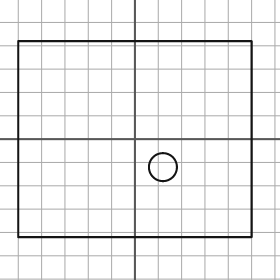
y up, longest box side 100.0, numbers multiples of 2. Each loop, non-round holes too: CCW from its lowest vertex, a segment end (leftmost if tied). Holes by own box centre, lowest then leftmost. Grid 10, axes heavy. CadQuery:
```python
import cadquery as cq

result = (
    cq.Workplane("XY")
    .moveTo(-50.0, -42.0)
    .lineTo(50.0, -42.0)
    .lineTo(50.0, 42.0)
    .lineTo(-50.0, 42.0)
    .close()
    .moveTo(12.0, -12.0)
    .circle(6.0)
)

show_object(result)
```